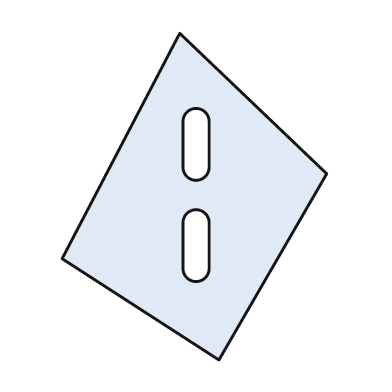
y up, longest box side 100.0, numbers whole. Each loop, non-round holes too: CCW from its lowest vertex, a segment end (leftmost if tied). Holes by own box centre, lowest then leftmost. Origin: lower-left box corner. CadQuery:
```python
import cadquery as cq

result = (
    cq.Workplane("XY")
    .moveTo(48.0, 0.0)
    .lineTo(81.0, 57.0)
    .lineTo(36.0, 100.0)
    .lineTo(0.0, 31.0)
    .close()
    .moveTo(37.0, 28.0)
    .threePointArc((41.0, 24.0), (45.0, 28.0))
    .lineTo(45.0, 42.0)
    .threePointArc((41.0, 46.0), (37.0, 42.0))
    .close()
    .moveTo(37.0, 59.0)
    .threePointArc((41.0, 55.0), (45.0, 59.0))
    .lineTo(45.0, 73.0)
    .threePointArc((41.0, 77.0), (37.0, 73.0))
    .close()
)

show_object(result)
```